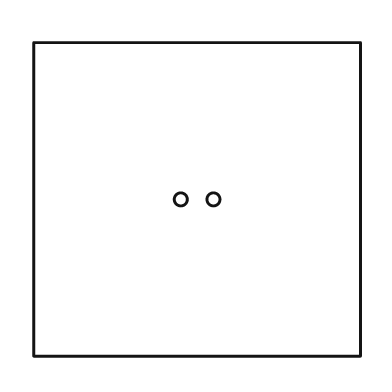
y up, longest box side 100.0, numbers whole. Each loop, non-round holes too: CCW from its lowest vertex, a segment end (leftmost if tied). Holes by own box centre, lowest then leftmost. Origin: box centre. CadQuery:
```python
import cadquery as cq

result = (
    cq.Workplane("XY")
    .moveTo(-50.0, -48.0)
    .lineTo(50.0, -48.0)
    .lineTo(50.0, 48.0)
    .lineTo(-50.0, 48.0)
    .close()
    .moveTo(-5.0, 0.0)
    .circle(2.0)
    .moveTo(5.0, 0.0)
    .circle(2.0)
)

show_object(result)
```